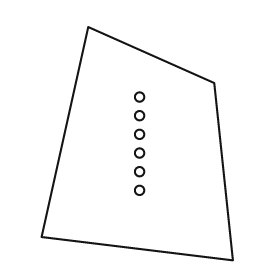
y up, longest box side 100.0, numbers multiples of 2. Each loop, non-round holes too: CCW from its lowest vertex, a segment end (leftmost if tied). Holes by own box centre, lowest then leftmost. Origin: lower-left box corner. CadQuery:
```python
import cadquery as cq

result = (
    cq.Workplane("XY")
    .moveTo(82.0, 0.0)
    .lineTo(74.0, 76.0)
    .lineTo(20.0, 100.0)
    .lineTo(0.0, 10.0)
    .close()
    .moveTo(42.0, 30.0)
    .circle(2.0)
    .moveTo(42.0, 38.0)
    .circle(2.0)
    .moveTo(42.0, 46.0)
    .circle(2.0)
    .moveTo(42.0, 54.0)
    .circle(2.0)
    .moveTo(42.0, 62.0)
    .circle(2.0)
    .moveTo(42.0, 70.0)
    .circle(2.0)
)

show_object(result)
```